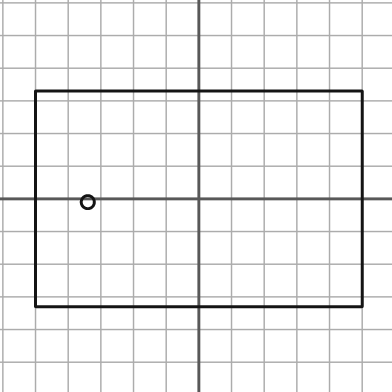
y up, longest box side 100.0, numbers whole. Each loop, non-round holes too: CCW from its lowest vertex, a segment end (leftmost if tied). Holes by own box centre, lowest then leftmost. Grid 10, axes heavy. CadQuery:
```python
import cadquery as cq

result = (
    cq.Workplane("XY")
    .moveTo(-50.0, -33.0)
    .lineTo(50.0, -33.0)
    .lineTo(50.0, 33.0)
    .lineTo(-50.0, 33.0)
    .close()
    .moveTo(-34.0, -1.0)
    .circle(2.0)
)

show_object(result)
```